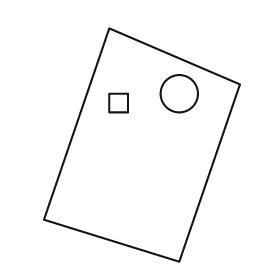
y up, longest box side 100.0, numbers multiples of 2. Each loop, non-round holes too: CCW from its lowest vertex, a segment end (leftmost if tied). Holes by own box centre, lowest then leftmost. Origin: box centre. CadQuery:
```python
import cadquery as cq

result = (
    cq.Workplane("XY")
    .moveTo(16.0, -50.0)
    .lineTo(42.0, 26.0)
    .lineTo(-14.0, 50.0)
    .lineTo(-42.0, -32.0)
    .close()
    .moveTo(-14.0, 14.0)
    .lineTo(-6.0, 14.0)
    .lineTo(-6.0, 22.0)
    .lineTo(-14.0, 22.0)
    .close()
    .moveTo(16.0, 22.0)
    .circle(8.0)
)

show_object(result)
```